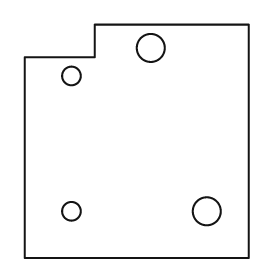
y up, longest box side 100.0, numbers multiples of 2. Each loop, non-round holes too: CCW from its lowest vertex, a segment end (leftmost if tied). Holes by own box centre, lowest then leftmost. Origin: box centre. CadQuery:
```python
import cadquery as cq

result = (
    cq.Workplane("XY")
    .moveTo(-48.0, -50.0)
    .lineTo(48.0, -50.0)
    .lineTo(48.0, 50.0)
    .lineTo(-18.0, 50.0)
    .lineTo(-18.0, 36.0)
    .lineTo(-48.0, 36.0)
    .close()
    .moveTo(-28.0, -30.0)
    .circle(4.0)
    .moveTo(30.0, -30.0)
    .circle(6.0)
    .moveTo(-28.0, 28.0)
    .circle(4.0)
    .moveTo(6.0, 40.0)
    .circle(6.0)
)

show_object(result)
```